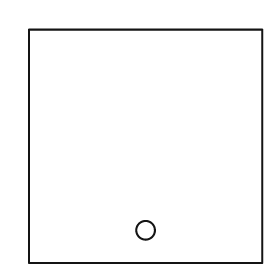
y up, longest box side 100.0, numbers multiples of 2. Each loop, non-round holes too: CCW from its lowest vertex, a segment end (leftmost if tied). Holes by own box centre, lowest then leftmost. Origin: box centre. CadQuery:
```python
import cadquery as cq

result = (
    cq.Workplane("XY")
    .moveTo(-50.0, -50.0)
    .lineTo(50.0, -50.0)
    .lineTo(50.0, 50.0)
    .lineTo(-50.0, 50.0)
    .close()
    .moveTo(0.0, -36.0)
    .circle(4.0)
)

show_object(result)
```